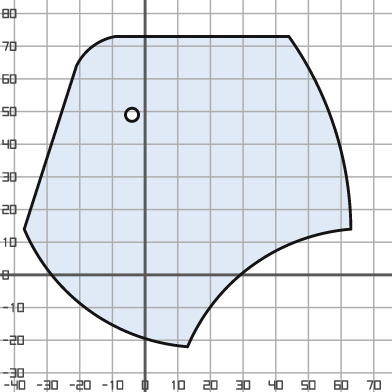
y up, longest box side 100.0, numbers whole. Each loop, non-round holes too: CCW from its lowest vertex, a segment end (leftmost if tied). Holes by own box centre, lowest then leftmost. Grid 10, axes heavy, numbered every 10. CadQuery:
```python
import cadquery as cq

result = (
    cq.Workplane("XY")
    .moveTo(13.0, -22.0)
    .threePointArc((33.0, 3.0), (63.0, 14.0))
    .threePointArc((58.0, 45.0), (44.0, 73.0))
    .lineTo(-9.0, 73.0)
    .threePointArc((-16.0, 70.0), (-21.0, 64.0))
    .lineTo(-37.0, 14.0)
    .threePointArc((-17.0, -11.0), (13.0, -22.0))
    .close()
    .moveTo(-4.0, 49.0)
    .circle(2.0)
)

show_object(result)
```